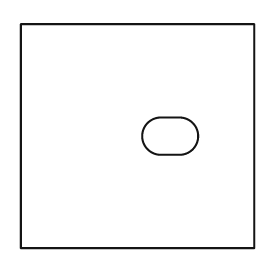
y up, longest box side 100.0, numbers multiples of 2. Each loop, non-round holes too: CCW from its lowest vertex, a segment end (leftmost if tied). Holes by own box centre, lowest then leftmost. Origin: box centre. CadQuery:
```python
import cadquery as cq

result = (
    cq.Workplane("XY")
    .moveTo(-50.0, -48.0)
    .lineTo(50.0, -48.0)
    .lineTo(50.0, 48.0)
    .lineTo(-50.0, 48.0)
    .close()
    .moveTo(10.0, -8.0)
    .lineTo(18.0, -8.0)
    .threePointArc((26.0, 0.0), (18.0, 8.0))
    .lineTo(10.0, 8.0)
    .threePointArc((2.0, 0.0), (10.0, -8.0))
    .close()
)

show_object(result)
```